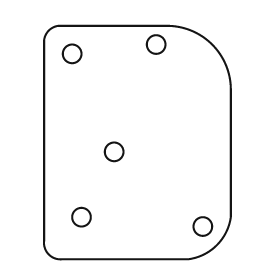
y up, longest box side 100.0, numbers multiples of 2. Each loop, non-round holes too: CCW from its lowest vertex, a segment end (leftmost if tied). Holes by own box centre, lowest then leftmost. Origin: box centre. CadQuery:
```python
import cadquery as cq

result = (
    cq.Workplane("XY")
    .moveTo(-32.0, -50.0)
    .lineTo(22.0, -50.0)
    .threePointArc((34.0, -44.0), (40.0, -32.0))
    .lineTo(40.0, 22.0)
    .threePointArc((32.0, 42.0), (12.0, 50.0))
    .lineTo(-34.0, 50.0)
    .threePointArc((-38.0, 48.0), (-40.0, 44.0))
    .lineTo(-40.0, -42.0)
    .threePointArc((-38.0, -48.0), (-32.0, -50.0))
    .close()
    .moveTo(28.0, -36.0)
    .circle(4.0)
    .moveTo(-24.0, -32.0)
    .circle(4.0)
    .moveTo(-10.0, -4.0)
    .circle(4.0)
    .moveTo(-28.0, 38.0)
    .circle(4.0)
    .moveTo(8.0, 42.0)
    .circle(4.0)
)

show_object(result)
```